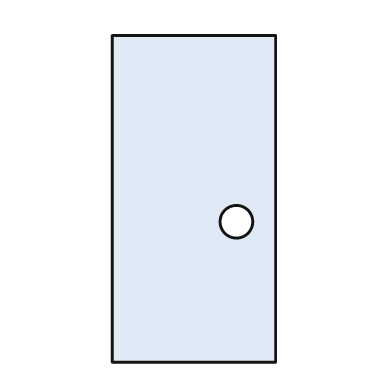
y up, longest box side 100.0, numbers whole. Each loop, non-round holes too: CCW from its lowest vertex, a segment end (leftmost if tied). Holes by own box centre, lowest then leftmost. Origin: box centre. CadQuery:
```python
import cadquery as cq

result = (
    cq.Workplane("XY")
    .moveTo(-25.0, -50.0)
    .lineTo(25.0, -50.0)
    .lineTo(25.0, 50.0)
    .lineTo(-25.0, 50.0)
    .close()
    .moveTo(13.0, -7.0)
    .circle(5.0)
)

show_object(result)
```